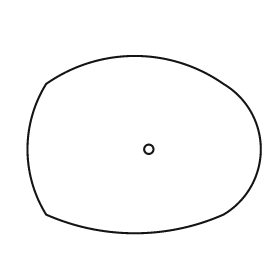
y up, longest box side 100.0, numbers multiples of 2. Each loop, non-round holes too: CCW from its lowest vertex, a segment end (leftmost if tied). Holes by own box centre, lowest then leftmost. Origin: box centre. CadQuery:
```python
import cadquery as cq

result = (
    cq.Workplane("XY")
    .moveTo(-42.0, -30.0)
    .threePointArc((-4.0, -38.0), (34.0, -30.0))
    .threePointArc((50.0, -2.0), (34.0, 26.0))
    .threePointArc((-4.0, 38.0), (-42.0, 26.0))
    .threePointArc((-50.0, -2.0), (-42.0, -30.0))
    .close()
    .moveTo(2.0, -2.0)
    .circle(2.0)
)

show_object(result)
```